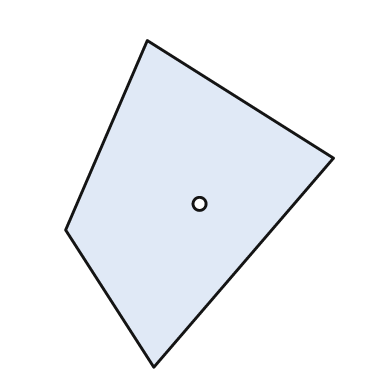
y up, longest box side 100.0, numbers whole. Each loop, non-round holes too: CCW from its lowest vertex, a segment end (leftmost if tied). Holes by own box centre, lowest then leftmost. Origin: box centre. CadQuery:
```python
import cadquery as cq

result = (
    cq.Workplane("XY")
    .moveTo(-14.0, -50.0)
    .lineTo(41.0, 14.0)
    .lineTo(-16.0, 50.0)
    .lineTo(-41.0, -8.0)
    .close()
    .moveTo(0.0, 0.0)
    .circle(2.0)
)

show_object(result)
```